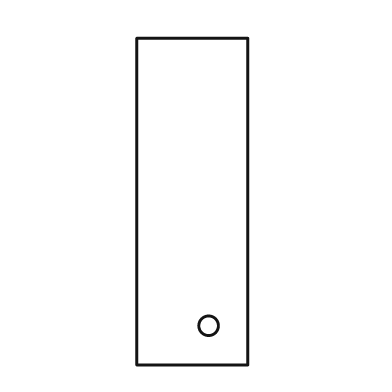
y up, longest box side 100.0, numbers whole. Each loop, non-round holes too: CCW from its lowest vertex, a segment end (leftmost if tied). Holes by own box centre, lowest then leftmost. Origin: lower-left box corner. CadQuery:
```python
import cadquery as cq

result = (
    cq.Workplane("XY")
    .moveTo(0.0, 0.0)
    .lineTo(34.0, 0.0)
    .lineTo(34.0, 100.0)
    .lineTo(0.0, 100.0)
    .close()
    .moveTo(22.0, 12.0)
    .circle(3.0)
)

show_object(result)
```